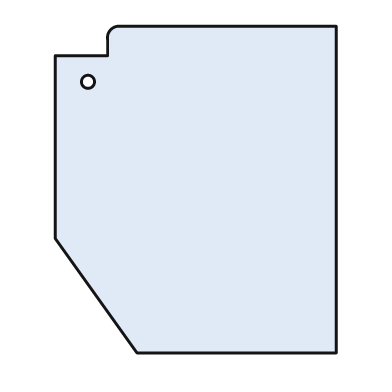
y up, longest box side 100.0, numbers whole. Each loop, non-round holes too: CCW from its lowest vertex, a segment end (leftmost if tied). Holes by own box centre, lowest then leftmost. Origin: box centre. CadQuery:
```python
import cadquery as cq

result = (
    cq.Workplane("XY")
    .moveTo(-18.0, -50.0)
    .lineTo(43.0, -50.0)
    .lineTo(43.0, 50.0)
    .lineTo(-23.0, 50.0)
    .threePointArc((-26.0, 49.0), (-27.0, 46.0))
    .lineTo(-27.0, 41.0)
    .lineTo(-43.0, 41.0)
    .lineTo(-43.0, -15.0)
    .close()
    .moveTo(-33.0, 33.0)
    .circle(2.0)
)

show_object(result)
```